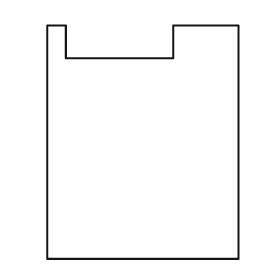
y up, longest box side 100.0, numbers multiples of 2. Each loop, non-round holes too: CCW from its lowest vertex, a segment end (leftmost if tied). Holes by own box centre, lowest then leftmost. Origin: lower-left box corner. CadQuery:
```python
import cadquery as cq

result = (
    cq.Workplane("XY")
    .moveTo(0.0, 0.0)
    .lineTo(82.0, 0.0)
    .lineTo(82.0, 100.0)
    .lineTo(54.0, 100.0)
    .lineTo(54.0, 86.0)
    .lineTo(8.0, 86.0)
    .lineTo(8.0, 100.0)
    .lineTo(0.0, 100.0)
    .close()
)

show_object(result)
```